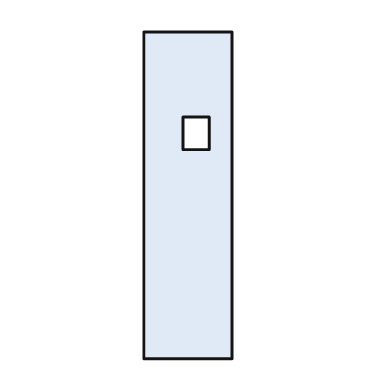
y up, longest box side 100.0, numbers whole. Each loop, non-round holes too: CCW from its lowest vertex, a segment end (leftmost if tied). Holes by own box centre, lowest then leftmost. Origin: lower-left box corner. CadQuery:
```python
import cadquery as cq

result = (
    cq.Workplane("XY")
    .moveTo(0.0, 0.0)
    .lineTo(27.0, 0.0)
    .lineTo(27.0, 100.0)
    .lineTo(0.0, 100.0)
    .close()
    .moveTo(12.0, 64.0)
    .lineTo(20.0, 64.0)
    .lineTo(20.0, 74.0)
    .lineTo(12.0, 74.0)
    .close()
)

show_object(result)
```